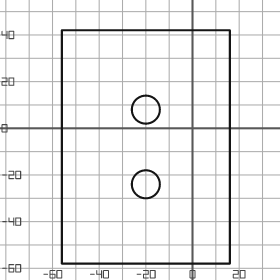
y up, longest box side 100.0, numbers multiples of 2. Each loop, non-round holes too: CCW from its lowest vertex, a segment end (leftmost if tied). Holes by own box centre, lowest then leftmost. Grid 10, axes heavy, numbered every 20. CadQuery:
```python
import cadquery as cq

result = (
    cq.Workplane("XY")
    .moveTo(-56.0, -58.0)
    .lineTo(16.0, -58.0)
    .lineTo(16.0, 42.0)
    .lineTo(-56.0, 42.0)
    .close()
    .moveTo(-20.0, -24.0)
    .circle(6.0)
    .moveTo(-20.0, 8.0)
    .circle(6.0)
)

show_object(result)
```